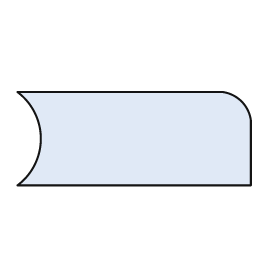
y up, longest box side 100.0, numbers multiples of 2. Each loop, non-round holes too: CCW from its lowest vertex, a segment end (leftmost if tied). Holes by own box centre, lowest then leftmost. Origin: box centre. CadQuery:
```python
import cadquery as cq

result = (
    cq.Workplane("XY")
    .moveTo(-50.0, -20.0)
    .lineTo(50.0, -20.0)
    .lineTo(50.0, 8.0)
    .threePointArc((46.0, 16.0), (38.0, 20.0))
    .lineTo(-50.0, 20.0)
    .threePointArc((-40.0, 0.0), (-50.0, -20.0))
    .close()
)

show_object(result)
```